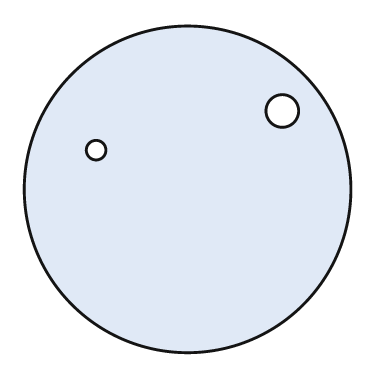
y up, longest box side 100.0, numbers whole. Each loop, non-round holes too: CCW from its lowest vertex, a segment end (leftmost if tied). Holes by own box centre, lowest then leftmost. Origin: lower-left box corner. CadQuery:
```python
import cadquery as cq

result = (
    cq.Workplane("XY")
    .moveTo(50.0, 50.0)
    .circle(50.0)
    .moveTo(22.0, 62.0)
    .circle(3.0)
    .moveTo(79.0, 74.0)
    .circle(5.0)
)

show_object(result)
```